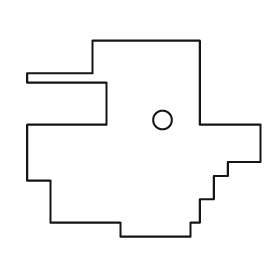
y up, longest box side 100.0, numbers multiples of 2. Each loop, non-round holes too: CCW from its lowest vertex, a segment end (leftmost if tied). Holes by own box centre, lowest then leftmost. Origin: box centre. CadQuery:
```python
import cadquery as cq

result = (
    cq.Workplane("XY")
    .moveTo(-10.0, -42.0)
    .lineTo(20.0, -42.0)
    .lineTo(20.0, -36.0)
    .lineTo(24.0, -36.0)
    .lineTo(24.0, -26.0)
    .lineTo(30.0, -26.0)
    .lineTo(30.0, -16.0)
    .lineTo(36.0, -16.0)
    .lineTo(36.0, -10.0)
    .lineTo(50.0, -10.0)
    .lineTo(50.0, 6.0)
    .lineTo(24.0, 6.0)
    .lineTo(24.0, 42.0)
    .lineTo(-22.0, 42.0)
    .lineTo(-22.0, 28.0)
    .lineTo(-50.0, 28.0)
    .lineTo(-50.0, 24.0)
    .lineTo(-16.0, 24.0)
    .lineTo(-16.0, 6.0)
    .lineTo(-50.0, 6.0)
    .lineTo(-50.0, -18.0)
    .lineTo(-40.0, -18.0)
    .lineTo(-40.0, -36.0)
    .lineTo(-10.0, -36.0)
    .close()
    .moveTo(8.0, 8.0)
    .circle(4.0)
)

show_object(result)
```